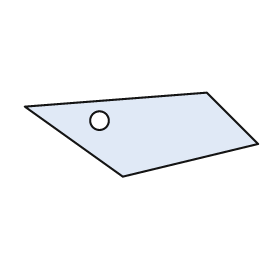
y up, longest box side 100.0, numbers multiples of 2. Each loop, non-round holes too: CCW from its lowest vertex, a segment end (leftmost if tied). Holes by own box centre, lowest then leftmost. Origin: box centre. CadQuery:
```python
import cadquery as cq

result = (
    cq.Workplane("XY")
    .moveTo(-8.0, -18.0)
    .lineTo(50.0, -4.0)
    .lineTo(28.0, 18.0)
    .lineTo(-50.0, 12.0)
    .close()
    .moveTo(-18.0, 6.0)
    .circle(4.0)
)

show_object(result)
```